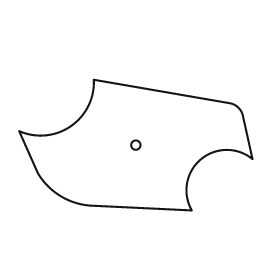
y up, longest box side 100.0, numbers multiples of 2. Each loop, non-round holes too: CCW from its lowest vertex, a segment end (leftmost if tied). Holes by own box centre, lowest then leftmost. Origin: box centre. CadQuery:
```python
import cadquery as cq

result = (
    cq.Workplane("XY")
    .moveTo(24.0, -28.0)
    .threePointArc((28.0, -6.0), (50.0, -6.0))
    .lineTo(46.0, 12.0)
    .threePointArc((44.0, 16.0), (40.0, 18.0))
    .lineTo(-18.0, 28.0)
    .threePointArc((-28.0, 8.0), (-50.0, 6.0))
    .lineTo(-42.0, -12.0)
    .threePointArc((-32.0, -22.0), (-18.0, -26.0))
    .close()
    .moveTo(0.0, 0.0)
    .circle(2.0)
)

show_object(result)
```